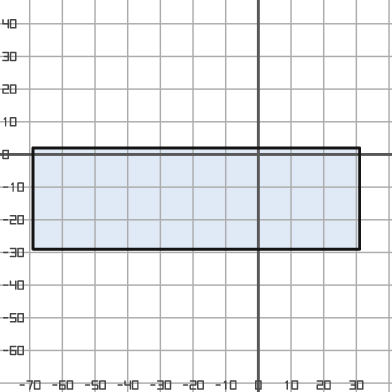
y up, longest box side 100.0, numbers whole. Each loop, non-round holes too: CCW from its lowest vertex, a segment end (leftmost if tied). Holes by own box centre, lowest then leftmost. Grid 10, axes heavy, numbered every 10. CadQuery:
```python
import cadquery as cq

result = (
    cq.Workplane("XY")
    .moveTo(-69.0, -29.0)
    .lineTo(31.0, -29.0)
    .lineTo(31.0, 2.0)
    .lineTo(-69.0, 2.0)
    .close()
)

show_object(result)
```